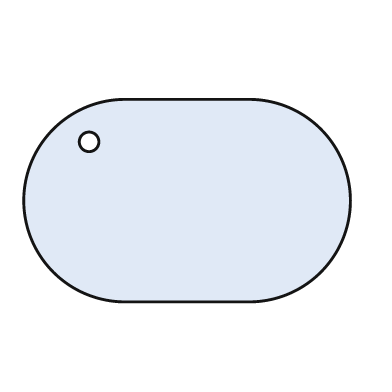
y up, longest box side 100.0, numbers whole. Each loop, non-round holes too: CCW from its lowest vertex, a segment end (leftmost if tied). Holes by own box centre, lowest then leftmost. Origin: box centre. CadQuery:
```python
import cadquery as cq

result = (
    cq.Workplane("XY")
    .moveTo(-19.0, -31.0)
    .lineTo(19.0, -31.0)
    .threePointArc((50.0, 0.0), (19.0, 31.0))
    .lineTo(-19.0, 31.0)
    .threePointArc((-50.0, 0.0), (-19.0, -31.0))
    .close()
    .moveTo(-30.0, 18.0)
    .circle(3.0)
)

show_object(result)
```